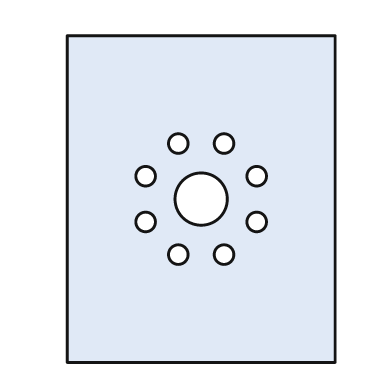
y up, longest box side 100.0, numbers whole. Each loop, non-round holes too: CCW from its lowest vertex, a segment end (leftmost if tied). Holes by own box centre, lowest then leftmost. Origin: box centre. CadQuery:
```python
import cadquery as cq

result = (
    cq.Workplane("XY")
    .moveTo(-41.0, -50.0)
    .lineTo(41.0, -50.0)
    .lineTo(41.0, 50.0)
    .lineTo(-41.0, 50.0)
    .close()
    .moveTo(-7.0, -17.0)
    .circle(3.0)
    .moveTo(7.0, -17.0)
    .circle(3.0)
    .moveTo(-17.0, -7.0)
    .circle(3.0)
    .moveTo(17.0, -7.0)
    .circle(3.0)
    .moveTo(0.0, 0.0)
    .circle(8.0)
    .moveTo(-17.0, 7.0)
    .circle(3.0)
    .moveTo(17.0, 7.0)
    .circle(3.0)
    .moveTo(-7.0, 17.0)
    .circle(3.0)
    .moveTo(7.0, 17.0)
    .circle(3.0)
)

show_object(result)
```